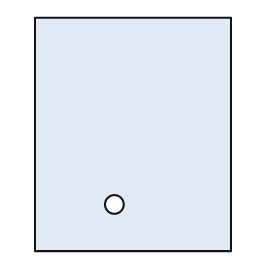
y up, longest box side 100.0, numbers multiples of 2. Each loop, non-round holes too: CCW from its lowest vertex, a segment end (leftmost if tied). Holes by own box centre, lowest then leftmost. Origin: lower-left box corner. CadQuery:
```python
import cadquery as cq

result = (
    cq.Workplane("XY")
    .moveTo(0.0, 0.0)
    .lineTo(84.0, 0.0)
    .lineTo(84.0, 100.0)
    .lineTo(0.0, 100.0)
    .close()
    .moveTo(34.0, 20.0)
    .circle(4.0)
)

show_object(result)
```